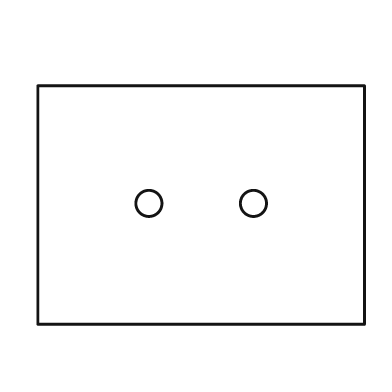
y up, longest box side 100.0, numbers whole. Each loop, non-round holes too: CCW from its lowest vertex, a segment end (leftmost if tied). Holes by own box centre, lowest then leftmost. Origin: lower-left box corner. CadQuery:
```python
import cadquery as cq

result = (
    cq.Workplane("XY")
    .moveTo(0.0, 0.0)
    .lineTo(100.0, 0.0)
    .lineTo(100.0, 73.0)
    .lineTo(0.0, 73.0)
    .close()
    .moveTo(34.0, 37.0)
    .circle(4.0)
    .moveTo(66.0, 37.0)
    .circle(4.0)
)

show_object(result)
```